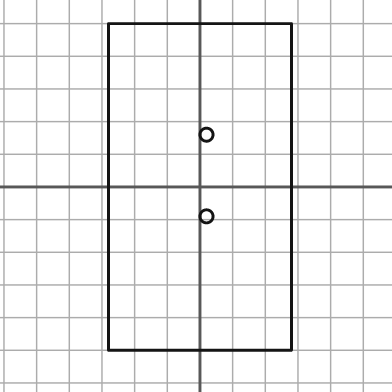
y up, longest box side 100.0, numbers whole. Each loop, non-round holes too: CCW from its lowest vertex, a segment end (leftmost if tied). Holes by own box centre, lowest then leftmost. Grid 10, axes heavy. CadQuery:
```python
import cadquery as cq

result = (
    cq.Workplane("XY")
    .moveTo(-28.0, -50.0)
    .lineTo(28.0, -50.0)
    .lineTo(28.0, 50.0)
    .lineTo(-28.0, 50.0)
    .close()
    .moveTo(2.0, -9.0)
    .circle(2.0)
    .moveTo(2.0, 16.0)
    .circle(2.0)
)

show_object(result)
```